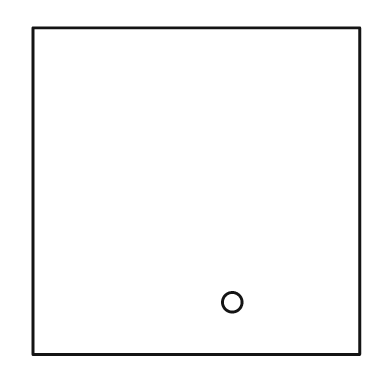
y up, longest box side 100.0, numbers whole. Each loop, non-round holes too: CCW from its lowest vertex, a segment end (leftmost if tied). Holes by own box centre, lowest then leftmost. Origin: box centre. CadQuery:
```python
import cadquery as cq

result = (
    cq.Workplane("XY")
    .moveTo(-50.0, -50.0)
    .lineTo(50.0, -50.0)
    .lineTo(50.0, 50.0)
    .lineTo(-50.0, 50.0)
    .close()
    .moveTo(11.0, -34.0)
    .circle(3.0)
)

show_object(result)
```